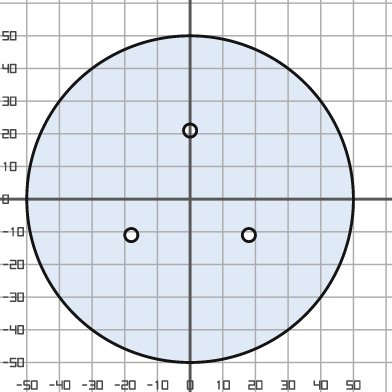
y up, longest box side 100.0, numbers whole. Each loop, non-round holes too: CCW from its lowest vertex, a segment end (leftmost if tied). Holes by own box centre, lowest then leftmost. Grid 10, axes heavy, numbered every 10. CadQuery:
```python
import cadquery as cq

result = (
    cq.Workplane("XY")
    .moveTo(0.0, 0.0)
    .circle(50.0)
    .moveTo(-18.0, -11.0)
    .circle(2.0)
    .moveTo(18.0, -11.0)
    .circle(2.0)
    .moveTo(0.0, 21.0)
    .circle(2.0)
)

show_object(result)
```